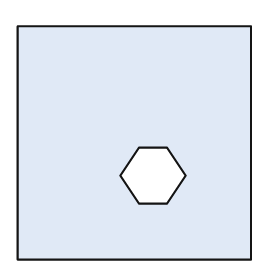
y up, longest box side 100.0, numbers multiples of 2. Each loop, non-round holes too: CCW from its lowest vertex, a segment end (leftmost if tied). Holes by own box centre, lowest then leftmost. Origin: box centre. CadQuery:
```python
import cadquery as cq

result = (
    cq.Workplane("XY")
    .moveTo(-50.0, -50.0)
    .lineTo(50.0, -50.0)
    .lineTo(50.0, 50.0)
    .lineTo(-50.0, 50.0)
    .close()
    .moveTo(2.0, -26.0)
    .lineTo(14.0, -26.0)
    .lineTo(22.0, -14.0)
    .lineTo(14.0, -2.0)
    .lineTo(2.0, -2.0)
    .lineTo(-6.0, -14.0)
    .close()
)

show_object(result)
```